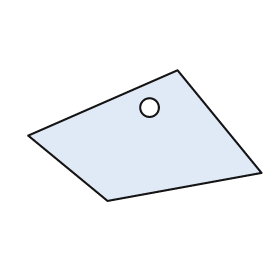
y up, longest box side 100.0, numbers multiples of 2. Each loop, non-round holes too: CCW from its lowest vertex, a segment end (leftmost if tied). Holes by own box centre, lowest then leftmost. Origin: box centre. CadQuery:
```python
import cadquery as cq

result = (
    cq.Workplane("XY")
    .moveTo(-16.0, -28.0)
    .lineTo(50.0, -16.0)
    .lineTo(14.0, 28.0)
    .lineTo(-50.0, 0.0)
    .close()
    .moveTo(2.0, 12.0)
    .circle(4.0)
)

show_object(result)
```